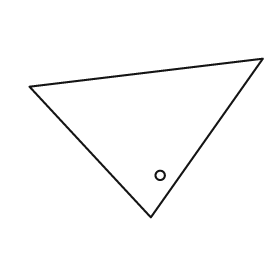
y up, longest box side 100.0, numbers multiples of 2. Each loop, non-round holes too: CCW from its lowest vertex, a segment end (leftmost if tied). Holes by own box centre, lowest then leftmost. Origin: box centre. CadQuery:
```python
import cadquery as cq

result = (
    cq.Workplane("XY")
    .moveTo(2.0, -34.0)
    .lineTo(50.0, 34.0)
    .lineTo(-50.0, 22.0)
    .close()
    .moveTo(6.0, -16.0)
    .circle(2.0)
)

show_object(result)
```